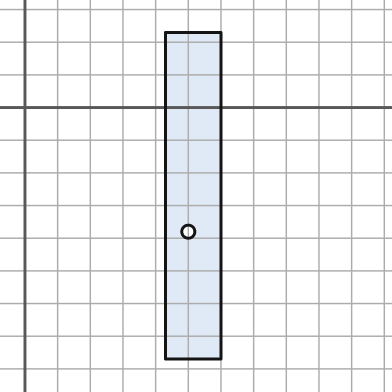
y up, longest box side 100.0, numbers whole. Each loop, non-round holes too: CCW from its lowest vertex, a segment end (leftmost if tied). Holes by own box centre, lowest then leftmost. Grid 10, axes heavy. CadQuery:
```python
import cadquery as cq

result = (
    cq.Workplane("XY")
    .moveTo(43.0, -77.0)
    .lineTo(60.0, -77.0)
    .lineTo(60.0, 23.0)
    .lineTo(43.0, 23.0)
    .close()
    .moveTo(50.0, -38.0)
    .circle(2.0)
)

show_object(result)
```